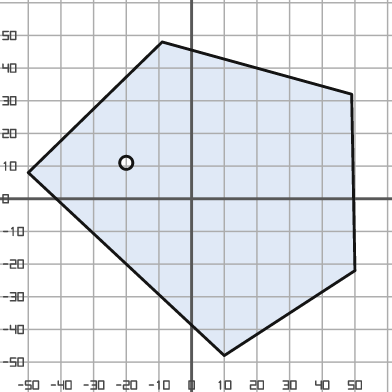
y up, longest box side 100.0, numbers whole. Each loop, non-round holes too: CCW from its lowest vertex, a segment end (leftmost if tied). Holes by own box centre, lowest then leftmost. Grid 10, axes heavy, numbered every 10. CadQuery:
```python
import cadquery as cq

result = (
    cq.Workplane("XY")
    .moveTo(10.0, -48.0)
    .lineTo(50.0, -22.0)
    .lineTo(49.0, 32.0)
    .lineTo(-9.0, 48.0)
    .lineTo(-50.0, 8.0)
    .close()
    .moveTo(-20.0, 11.0)
    .circle(2.0)
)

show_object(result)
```